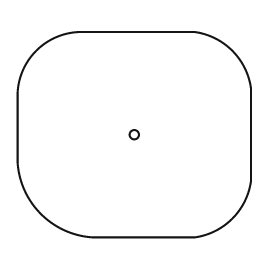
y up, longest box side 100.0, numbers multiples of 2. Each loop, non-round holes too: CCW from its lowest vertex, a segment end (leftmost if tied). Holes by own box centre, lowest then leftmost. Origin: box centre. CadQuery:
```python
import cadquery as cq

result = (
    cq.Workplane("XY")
    .moveTo(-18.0, -44.0)
    .lineTo(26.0, -44.0)
    .threePointArc((42.0, -36.0), (50.0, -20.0))
    .lineTo(50.0, 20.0)
    .threePointArc((42.0, 36.0), (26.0, 44.0))
    .lineTo(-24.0, 44.0)
    .threePointArc((-42.0, 36.0), (-50.0, 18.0))
    .lineTo(-50.0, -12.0)
    .threePointArc((-40.0, -34.0), (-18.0, -44.0))
    .close()
    .moveTo(0.0, 0.0)
    .circle(2.0)
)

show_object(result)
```